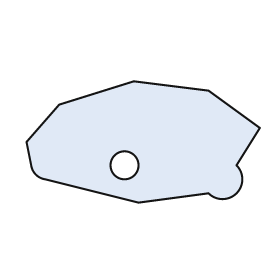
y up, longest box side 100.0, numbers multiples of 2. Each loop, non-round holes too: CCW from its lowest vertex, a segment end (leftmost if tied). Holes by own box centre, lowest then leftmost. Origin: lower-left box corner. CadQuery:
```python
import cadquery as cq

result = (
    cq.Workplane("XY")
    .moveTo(48.0, 0.0)
    .lineTo(78.0, 4.0)
    .threePointArc((90.0, 4.0), (90.0, 16.0))
    .lineTo(100.0, 32.0)
    .lineTo(78.0, 48.0)
    .lineTo(46.0, 52.0)
    .lineTo(14.0, 42.0)
    .lineTo(0.0, 26.0)
    .lineTo(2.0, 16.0)
    .threePointArc((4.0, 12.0), (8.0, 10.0))
    .close()
    .moveTo(42.0, 16.0)
    .circle(6.0)
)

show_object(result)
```